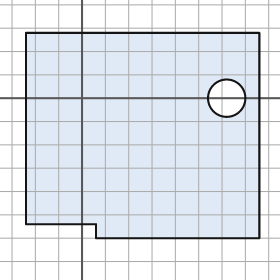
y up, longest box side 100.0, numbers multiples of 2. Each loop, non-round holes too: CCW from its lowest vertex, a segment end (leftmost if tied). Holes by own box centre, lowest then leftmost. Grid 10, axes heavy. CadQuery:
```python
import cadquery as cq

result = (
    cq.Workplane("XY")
    .moveTo(6.0, -60.0)
    .lineTo(76.0, -60.0)
    .lineTo(76.0, 28.0)
    .lineTo(-24.0, 28.0)
    .lineTo(-24.0, -54.0)
    .lineTo(6.0, -54.0)
    .close()
    .moveTo(62.0, 0.0)
    .circle(8.0)
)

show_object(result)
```